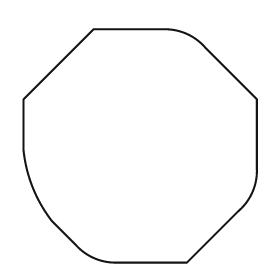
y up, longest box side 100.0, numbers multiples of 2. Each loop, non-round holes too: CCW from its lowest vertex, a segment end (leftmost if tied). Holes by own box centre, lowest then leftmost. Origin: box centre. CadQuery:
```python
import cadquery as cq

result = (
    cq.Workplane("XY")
    .moveTo(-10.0, -50.0)
    .lineTo(20.0, -50.0)
    .lineTo(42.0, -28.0)
    .threePointArc((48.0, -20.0), (50.0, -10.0))
    .lineTo(50.0, 20.0)
    .lineTo(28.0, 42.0)
    .threePointArc((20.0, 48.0), (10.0, 50.0))
    .lineTo(-20.0, 50.0)
    .lineTo(-50.0, 20.0)
    .lineTo(-50.0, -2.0)
    .threePointArc((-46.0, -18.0), (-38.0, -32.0))
    .lineTo(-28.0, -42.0)
    .threePointArc((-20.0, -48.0), (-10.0, -50.0))
    .close()
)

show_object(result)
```